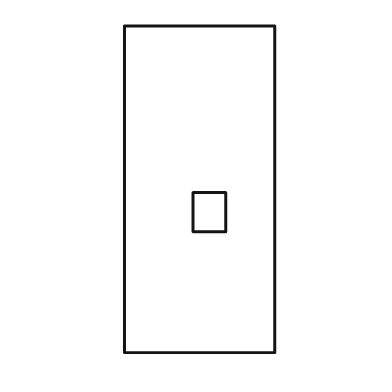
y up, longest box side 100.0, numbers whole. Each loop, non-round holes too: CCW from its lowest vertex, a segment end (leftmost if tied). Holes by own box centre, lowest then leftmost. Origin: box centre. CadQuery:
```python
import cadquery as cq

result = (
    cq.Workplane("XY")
    .moveTo(-23.0, -50.0)
    .lineTo(23.0, -50.0)
    .lineTo(23.0, 50.0)
    .lineTo(-23.0, 50.0)
    .close()
    .moveTo(-2.0, -13.0)
    .lineTo(8.0, -13.0)
    .lineTo(8.0, -1.0)
    .lineTo(-2.0, -1.0)
    .close()
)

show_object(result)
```